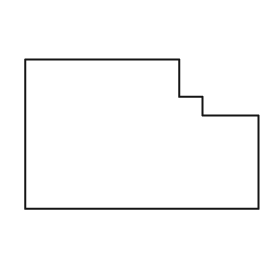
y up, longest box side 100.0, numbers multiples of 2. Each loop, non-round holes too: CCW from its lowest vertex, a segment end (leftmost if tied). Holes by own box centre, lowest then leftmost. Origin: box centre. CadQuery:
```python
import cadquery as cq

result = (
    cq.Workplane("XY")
    .moveTo(-50.0, -32.0)
    .lineTo(50.0, -32.0)
    .lineTo(50.0, 8.0)
    .lineTo(26.0, 8.0)
    .lineTo(26.0, 16.0)
    .lineTo(16.0, 16.0)
    .lineTo(16.0, 32.0)
    .lineTo(-50.0, 32.0)
    .close()
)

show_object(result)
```